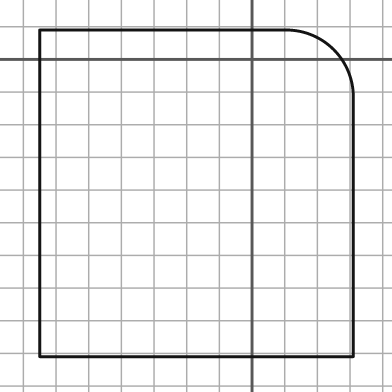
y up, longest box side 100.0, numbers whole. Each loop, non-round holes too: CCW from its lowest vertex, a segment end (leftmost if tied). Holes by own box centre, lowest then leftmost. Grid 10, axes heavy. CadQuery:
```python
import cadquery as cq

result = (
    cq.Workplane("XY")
    .moveTo(-65.0, -91.0)
    .lineTo(31.0, -91.0)
    .lineTo(31.0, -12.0)
    .threePointArc((25.0, 3.0), (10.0, 9.0))
    .lineTo(-65.0, 9.0)
    .close()
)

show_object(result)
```